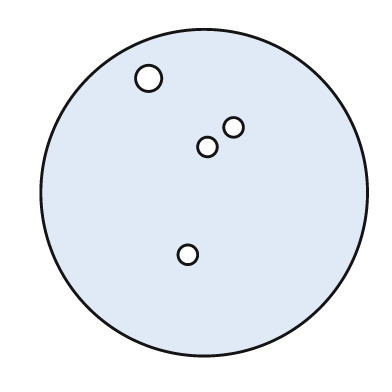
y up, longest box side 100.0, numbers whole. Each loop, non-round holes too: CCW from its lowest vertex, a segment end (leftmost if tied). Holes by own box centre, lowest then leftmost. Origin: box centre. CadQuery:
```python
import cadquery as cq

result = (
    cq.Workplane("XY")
    .moveTo(0.0, 0.0)
    .circle(50.0)
    .moveTo(-5.0, -19.0)
    .circle(3.0)
    .moveTo(1.0, 14.0)
    .circle(3.0)
    .moveTo(9.0, 20.0)
    .circle(3.0)
    .moveTo(-17.0, 35.0)
    .circle(4.0)
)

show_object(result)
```